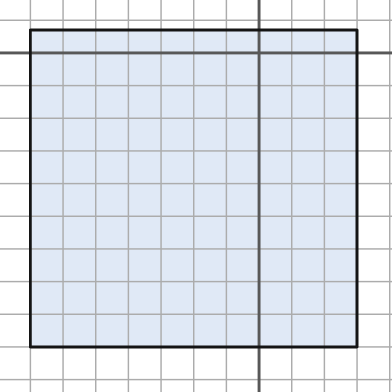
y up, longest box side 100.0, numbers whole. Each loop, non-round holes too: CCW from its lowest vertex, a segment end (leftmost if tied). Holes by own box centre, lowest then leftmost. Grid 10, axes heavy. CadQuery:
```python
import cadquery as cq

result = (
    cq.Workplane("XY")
    .moveTo(-70.0, -90.0)
    .lineTo(30.0, -90.0)
    .lineTo(30.0, 7.0)
    .lineTo(-70.0, 7.0)
    .close()
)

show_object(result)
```